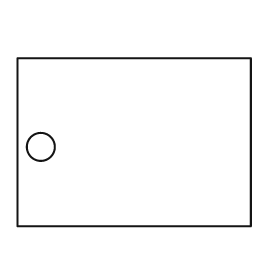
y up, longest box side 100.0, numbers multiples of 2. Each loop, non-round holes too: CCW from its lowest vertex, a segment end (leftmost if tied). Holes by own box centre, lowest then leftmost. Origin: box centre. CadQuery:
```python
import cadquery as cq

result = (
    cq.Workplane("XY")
    .moveTo(-50.0, -36.0)
    .lineTo(50.0, -36.0)
    .lineTo(50.0, 36.0)
    .lineTo(-50.0, 36.0)
    .close()
    .moveTo(-40.0, -2.0)
    .circle(6.0)
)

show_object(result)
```